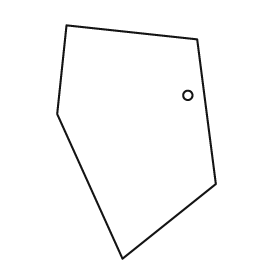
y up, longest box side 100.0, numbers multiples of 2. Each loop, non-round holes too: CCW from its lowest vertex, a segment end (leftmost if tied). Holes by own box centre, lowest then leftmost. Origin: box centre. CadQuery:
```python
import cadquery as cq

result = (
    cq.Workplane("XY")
    .moveTo(-6.0, -50.0)
    .lineTo(34.0, -18.0)
    .lineTo(26.0, 44.0)
    .lineTo(-30.0, 50.0)
    .lineTo(-34.0, 12.0)
    .close()
    .moveTo(22.0, 20.0)
    .circle(2.0)
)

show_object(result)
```